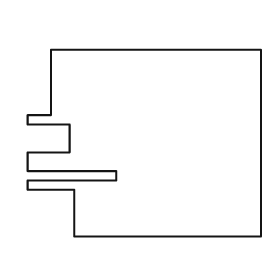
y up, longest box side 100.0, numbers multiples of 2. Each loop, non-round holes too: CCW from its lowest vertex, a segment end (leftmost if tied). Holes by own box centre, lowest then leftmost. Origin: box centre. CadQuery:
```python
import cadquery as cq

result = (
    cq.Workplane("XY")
    .moveTo(-30.0, -40.0)
    .lineTo(50.0, -40.0)
    .lineTo(50.0, 40.0)
    .lineTo(-40.0, 40.0)
    .lineTo(-40.0, 12.0)
    .lineTo(-50.0, 12.0)
    .lineTo(-50.0, 8.0)
    .lineTo(-32.0, 8.0)
    .lineTo(-32.0, -4.0)
    .lineTo(-50.0, -4.0)
    .lineTo(-50.0, -12.0)
    .lineTo(-12.0, -12.0)
    .lineTo(-12.0, -16.0)
    .lineTo(-50.0, -16.0)
    .lineTo(-50.0, -20.0)
    .lineTo(-30.0, -20.0)
    .close()
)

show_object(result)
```